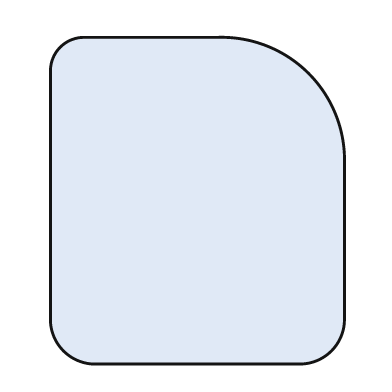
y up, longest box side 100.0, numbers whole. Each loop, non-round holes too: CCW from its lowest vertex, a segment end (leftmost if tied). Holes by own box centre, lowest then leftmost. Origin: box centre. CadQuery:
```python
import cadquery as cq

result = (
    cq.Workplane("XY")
    .moveTo(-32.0, -50.0)
    .lineTo(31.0, -50.0)
    .threePointArc((41.0, -46.0), (45.0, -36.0))
    .lineTo(45.0, 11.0)
    .threePointArc((34.0, 39.0), (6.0, 50.0))
    .lineTo(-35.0, 50.0)
    .threePointArc((-42.0, 47.0), (-45.0, 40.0))
    .lineTo(-45.0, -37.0)
    .threePointArc((-41.0, -46.0), (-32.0, -50.0))
    .close()
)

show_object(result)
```